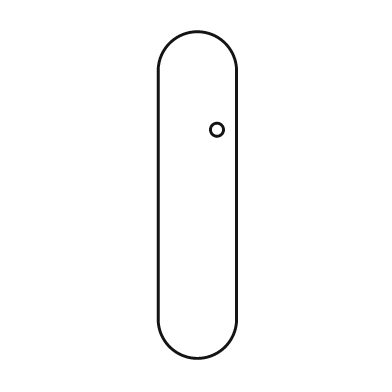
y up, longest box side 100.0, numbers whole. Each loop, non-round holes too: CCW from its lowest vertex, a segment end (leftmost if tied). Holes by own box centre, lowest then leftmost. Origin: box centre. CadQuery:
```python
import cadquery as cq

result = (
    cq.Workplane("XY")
    .moveTo(-12.0, -38.0)
    .threePointArc((0.0, -50.0), (12.0, -38.0))
    .lineTo(12.0, 38.0)
    .threePointArc((0.0, 50.0), (-12.0, 38.0))
    .close()
    .moveTo(6.0, 20.0)
    .circle(2.0)
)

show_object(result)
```